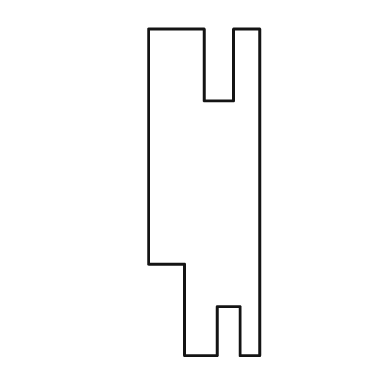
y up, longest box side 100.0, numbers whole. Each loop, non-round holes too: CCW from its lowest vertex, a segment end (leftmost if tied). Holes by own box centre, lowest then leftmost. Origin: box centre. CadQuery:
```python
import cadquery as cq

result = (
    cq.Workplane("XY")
    .moveTo(-6.0, -50.0)
    .lineTo(4.0, -50.0)
    .lineTo(4.0, -35.0)
    .lineTo(11.0, -35.0)
    .lineTo(11.0, -50.0)
    .lineTo(17.0, -50.0)
    .lineTo(17.0, 50.0)
    .lineTo(9.0, 50.0)
    .lineTo(9.0, 28.0)
    .lineTo(0.0, 28.0)
    .lineTo(0.0, 50.0)
    .lineTo(-17.0, 50.0)
    .lineTo(-17.0, -22.0)
    .lineTo(-6.0, -22.0)
    .close()
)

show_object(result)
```